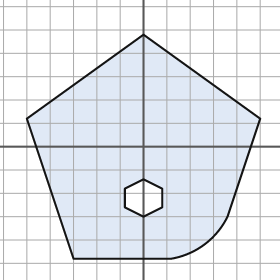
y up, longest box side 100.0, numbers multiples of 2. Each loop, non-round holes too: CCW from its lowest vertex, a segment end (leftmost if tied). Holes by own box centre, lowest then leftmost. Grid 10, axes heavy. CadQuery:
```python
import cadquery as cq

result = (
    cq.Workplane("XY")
    .moveTo(-30.0, -48.0)
    .lineTo(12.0, -48.0)
    .threePointArc((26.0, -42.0), (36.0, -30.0))
    .lineTo(50.0, 12.0)
    .lineTo(0.0, 48.0)
    .lineTo(-50.0, 12.0)
    .close()
    .moveTo(0.0, -30.0)
    .lineTo(8.0, -26.0)
    .lineTo(8.0, -18.0)
    .lineTo(0.0, -14.0)
    .lineTo(-8.0, -18.0)
    .lineTo(-8.0, -26.0)
    .close()
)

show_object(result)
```